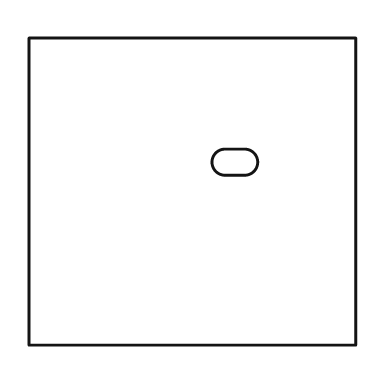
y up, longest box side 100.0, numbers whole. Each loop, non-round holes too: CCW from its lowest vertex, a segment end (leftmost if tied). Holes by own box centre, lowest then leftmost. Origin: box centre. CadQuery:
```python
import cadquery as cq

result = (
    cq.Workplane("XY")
    .moveTo(-50.0, -47.0)
    .lineTo(50.0, -47.0)
    .lineTo(50.0, 47.0)
    .lineTo(-50.0, 47.0)
    .close()
    .moveTo(10.0, 5.0)
    .lineTo(16.0, 5.0)
    .threePointArc((20.0, 9.0), (16.0, 13.0))
    .lineTo(10.0, 13.0)
    .threePointArc((6.0, 9.0), (10.0, 5.0))
    .close()
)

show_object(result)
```